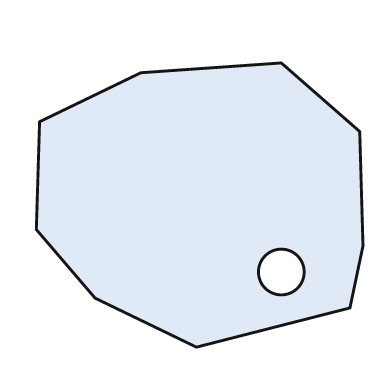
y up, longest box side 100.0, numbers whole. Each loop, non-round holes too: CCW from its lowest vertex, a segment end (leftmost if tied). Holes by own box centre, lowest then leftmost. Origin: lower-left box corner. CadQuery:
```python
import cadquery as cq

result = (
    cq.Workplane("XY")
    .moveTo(49.0, 0.0)
    .lineTo(96.0, 12.0)
    .lineTo(100.0, 31.0)
    .lineTo(99.0, 66.0)
    .lineTo(75.0, 87.0)
    .lineTo(32.0, 84.0)
    .lineTo(1.0, 69.0)
    .lineTo(0.0, 36.0)
    .lineTo(18.0, 15.0)
    .close()
    .moveTo(75.0, 23.0)
    .circle(7.0)
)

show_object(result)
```